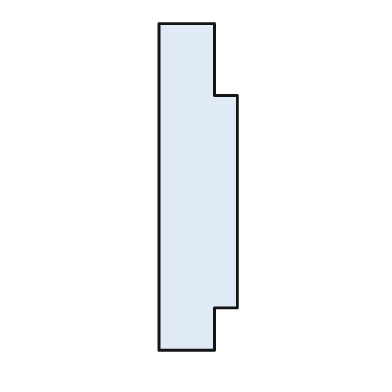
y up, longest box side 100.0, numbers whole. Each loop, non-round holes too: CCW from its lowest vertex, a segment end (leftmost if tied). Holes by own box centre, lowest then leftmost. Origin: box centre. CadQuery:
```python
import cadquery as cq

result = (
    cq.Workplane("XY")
    .moveTo(-12.0, -50.0)
    .lineTo(5.0, -50.0)
    .lineTo(5.0, -37.0)
    .lineTo(12.0, -37.0)
    .lineTo(12.0, 28.0)
    .lineTo(5.0, 28.0)
    .lineTo(5.0, 50.0)
    .lineTo(-12.0, 50.0)
    .close()
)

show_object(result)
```